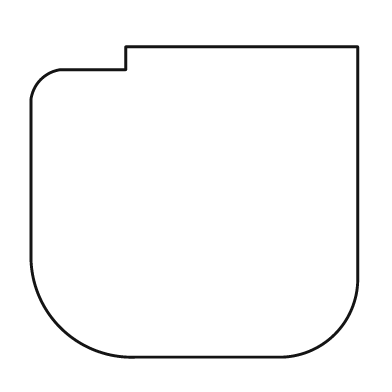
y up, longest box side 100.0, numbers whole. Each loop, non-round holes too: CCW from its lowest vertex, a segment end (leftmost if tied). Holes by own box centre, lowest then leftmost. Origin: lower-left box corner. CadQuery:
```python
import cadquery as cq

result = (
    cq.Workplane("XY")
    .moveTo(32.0, 0.0)
    .lineTo(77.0, 0.0)
    .threePointArc((93.0, 7.0), (100.0, 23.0))
    .lineTo(100.0, 95.0)
    .lineTo(29.0, 95.0)
    .lineTo(29.0, 88.0)
    .lineTo(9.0, 88.0)
    .threePointArc((3.0, 85.0), (0.0, 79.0))
    .lineTo(0.0, 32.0)
    .threePointArc((9.0, 9.0), (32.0, 0.0))
    .close()
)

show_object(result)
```